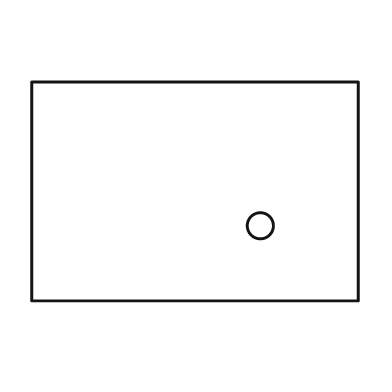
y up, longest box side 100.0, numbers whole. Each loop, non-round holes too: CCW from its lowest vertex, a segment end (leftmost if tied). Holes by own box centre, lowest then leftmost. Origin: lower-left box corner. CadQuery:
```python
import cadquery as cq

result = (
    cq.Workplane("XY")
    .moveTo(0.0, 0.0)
    .lineTo(100.0, 0.0)
    .lineTo(100.0, 67.0)
    .lineTo(0.0, 67.0)
    .close()
    .moveTo(70.0, 23.0)
    .circle(4.0)
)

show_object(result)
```